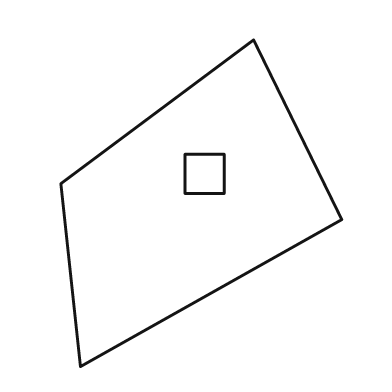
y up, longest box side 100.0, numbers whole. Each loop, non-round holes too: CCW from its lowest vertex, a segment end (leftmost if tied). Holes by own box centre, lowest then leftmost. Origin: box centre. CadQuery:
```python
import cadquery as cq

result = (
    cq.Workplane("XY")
    .moveTo(-37.0, -50.0)
    .lineTo(43.0, -5.0)
    .lineTo(16.0, 50.0)
    .lineTo(-43.0, 6.0)
    .close()
    .moveTo(-5.0, 3.0)
    .lineTo(7.0, 3.0)
    .lineTo(7.0, 15.0)
    .lineTo(-5.0, 15.0)
    .close()
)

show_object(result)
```